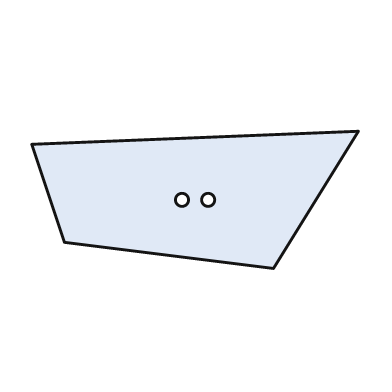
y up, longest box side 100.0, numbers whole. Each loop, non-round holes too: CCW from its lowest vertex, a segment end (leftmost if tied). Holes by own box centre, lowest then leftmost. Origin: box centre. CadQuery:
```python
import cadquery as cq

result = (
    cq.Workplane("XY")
    .moveTo(24.0, -21.0)
    .lineTo(50.0, 21.0)
    .lineTo(-50.0, 17.0)
    .lineTo(-40.0, -13.0)
    .close()
    .moveTo(-4.0, 0.0)
    .circle(2.0)
    .moveTo(4.0, 0.0)
    .circle(2.0)
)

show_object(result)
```